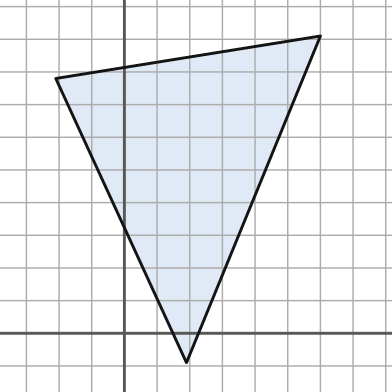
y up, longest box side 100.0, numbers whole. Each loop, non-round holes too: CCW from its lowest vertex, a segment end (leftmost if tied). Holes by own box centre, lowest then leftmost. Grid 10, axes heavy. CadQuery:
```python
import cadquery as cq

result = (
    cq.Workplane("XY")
    .moveTo(19.0, -9.0)
    .lineTo(60.0, 91.0)
    .lineTo(-21.0, 78.0)
    .close()
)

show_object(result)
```